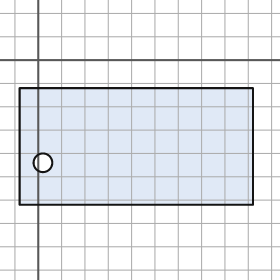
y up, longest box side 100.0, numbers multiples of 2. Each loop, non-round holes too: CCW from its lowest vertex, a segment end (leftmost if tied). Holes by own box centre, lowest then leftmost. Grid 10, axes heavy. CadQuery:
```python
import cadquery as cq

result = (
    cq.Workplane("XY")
    .moveTo(-8.0, -62.0)
    .lineTo(92.0, -62.0)
    .lineTo(92.0, -12.0)
    .lineTo(-8.0, -12.0)
    .close()
    .moveTo(2.0, -44.0)
    .circle(4.0)
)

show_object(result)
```